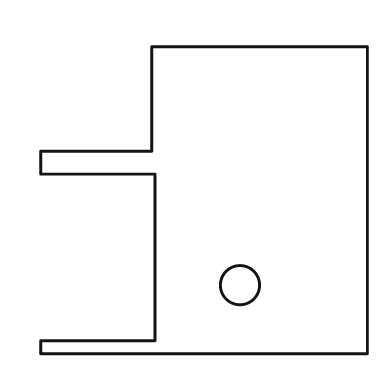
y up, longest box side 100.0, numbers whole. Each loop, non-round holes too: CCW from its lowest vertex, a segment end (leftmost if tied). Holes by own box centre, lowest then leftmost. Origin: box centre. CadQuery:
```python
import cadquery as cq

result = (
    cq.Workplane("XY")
    .moveTo(-50.0, -47.0)
    .lineTo(50.0, -47.0)
    .lineTo(50.0, 47.0)
    .lineTo(-16.0, 47.0)
    .lineTo(-16.0, 15.0)
    .lineTo(-50.0, 15.0)
    .lineTo(-50.0, 8.0)
    .lineTo(-15.0, 8.0)
    .lineTo(-15.0, -43.0)
    .lineTo(-50.0, -43.0)
    .close()
    .moveTo(11.0, -26.0)
    .circle(6.0)
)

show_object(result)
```